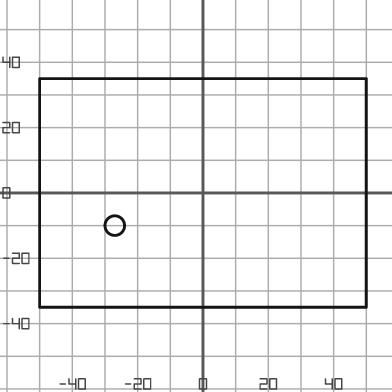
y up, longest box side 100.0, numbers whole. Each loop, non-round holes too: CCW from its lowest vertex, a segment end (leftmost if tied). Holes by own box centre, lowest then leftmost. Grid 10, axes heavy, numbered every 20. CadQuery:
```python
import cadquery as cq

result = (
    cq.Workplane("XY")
    .moveTo(-50.0, -35.0)
    .lineTo(50.0, -35.0)
    .lineTo(50.0, 35.0)
    .lineTo(-50.0, 35.0)
    .close()
    .moveTo(-27.0, -10.0)
    .circle(3.0)
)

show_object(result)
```